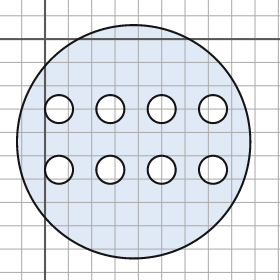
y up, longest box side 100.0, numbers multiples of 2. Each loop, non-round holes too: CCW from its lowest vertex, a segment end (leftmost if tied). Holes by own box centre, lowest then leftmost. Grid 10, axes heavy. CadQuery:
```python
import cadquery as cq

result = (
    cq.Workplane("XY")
    .moveTo(38.0, -44.0)
    .circle(50.0)
    .moveTo(6.0, -56.0)
    .circle(6.0)
    .moveTo(28.0, -56.0)
    .circle(6.0)
    .moveTo(50.0, -56.0)
    .circle(6.0)
    .moveTo(72.0, -56.0)
    .circle(6.0)
    .moveTo(6.0, -30.0)
    .circle(6.0)
    .moveTo(28.0, -30.0)
    .circle(6.0)
    .moveTo(50.0, -30.0)
    .circle(6.0)
    .moveTo(72.0, -30.0)
    .circle(6.0)
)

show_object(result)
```